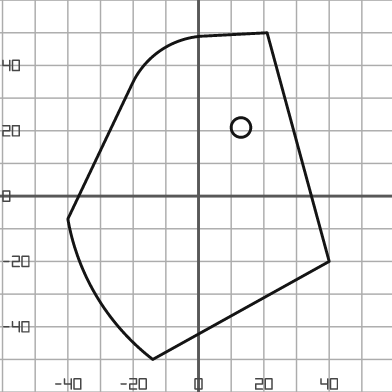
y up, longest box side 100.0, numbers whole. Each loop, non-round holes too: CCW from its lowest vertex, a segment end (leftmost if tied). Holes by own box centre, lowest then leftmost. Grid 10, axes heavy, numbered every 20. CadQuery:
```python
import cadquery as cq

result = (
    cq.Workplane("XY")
    .moveTo(-14.0, -50.0)
    .lineTo(40.0, -20.0)
    .lineTo(21.0, 50.0)
    .lineTo(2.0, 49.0)
    .threePointArc((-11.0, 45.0), (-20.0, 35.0))
    .lineTo(-40.0, -7.0)
    .threePointArc((-31.0, -31.0), (-14.0, -50.0))
    .close()
    .moveTo(13.0, 21.0)
    .circle(3.0)
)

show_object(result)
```